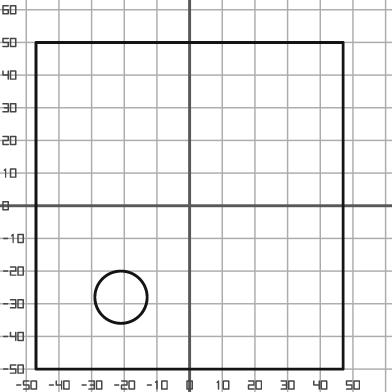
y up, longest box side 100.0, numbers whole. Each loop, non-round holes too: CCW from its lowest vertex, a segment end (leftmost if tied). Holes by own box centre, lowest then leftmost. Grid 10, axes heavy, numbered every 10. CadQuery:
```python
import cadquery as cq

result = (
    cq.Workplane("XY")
    .moveTo(-47.0, -50.0)
    .lineTo(47.0, -50.0)
    .lineTo(47.0, 50.0)
    .lineTo(-47.0, 50.0)
    .close()
    .moveTo(-21.0, -28.0)
    .circle(8.0)
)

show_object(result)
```